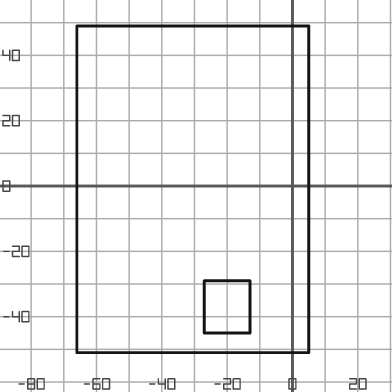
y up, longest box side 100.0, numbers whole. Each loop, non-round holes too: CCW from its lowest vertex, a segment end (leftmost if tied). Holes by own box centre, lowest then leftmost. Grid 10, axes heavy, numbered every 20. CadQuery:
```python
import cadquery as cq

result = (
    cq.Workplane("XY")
    .moveTo(-66.0, -51.0)
    .lineTo(5.0, -51.0)
    .lineTo(5.0, 49.0)
    .lineTo(-66.0, 49.0)
    .close()
    .moveTo(-27.0, -45.0)
    .lineTo(-13.0, -45.0)
    .lineTo(-13.0, -29.0)
    .lineTo(-27.0, -29.0)
    .close()
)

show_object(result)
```